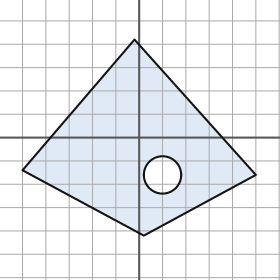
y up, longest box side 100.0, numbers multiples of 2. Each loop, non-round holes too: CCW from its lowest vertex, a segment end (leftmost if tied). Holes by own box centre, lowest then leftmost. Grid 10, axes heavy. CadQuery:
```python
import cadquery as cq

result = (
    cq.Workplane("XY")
    .moveTo(2.0, -42.0)
    .lineTo(50.0, -16.0)
    .lineTo(-2.0, 42.0)
    .lineTo(-50.0, -14.0)
    .close()
    .moveTo(10.0, -16.0)
    .circle(8.0)
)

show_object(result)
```